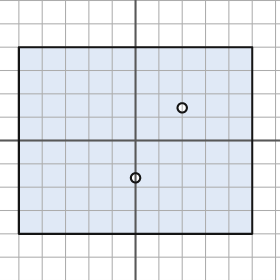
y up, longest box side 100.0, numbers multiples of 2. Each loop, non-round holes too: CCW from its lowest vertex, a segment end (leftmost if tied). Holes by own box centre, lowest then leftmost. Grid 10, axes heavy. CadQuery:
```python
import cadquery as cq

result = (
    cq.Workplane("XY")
    .moveTo(-50.0, -40.0)
    .lineTo(50.0, -40.0)
    .lineTo(50.0, 40.0)
    .lineTo(-50.0, 40.0)
    .close()
    .moveTo(0.0, -16.0)
    .circle(2.0)
    .moveTo(20.0, 14.0)
    .circle(2.0)
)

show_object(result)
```